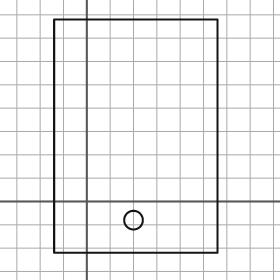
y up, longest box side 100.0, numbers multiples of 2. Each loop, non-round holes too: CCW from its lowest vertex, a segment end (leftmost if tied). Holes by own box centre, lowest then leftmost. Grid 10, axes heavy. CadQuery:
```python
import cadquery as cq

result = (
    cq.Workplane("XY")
    .moveTo(-14.0, -22.0)
    .lineTo(56.0, -22.0)
    .lineTo(56.0, 78.0)
    .lineTo(-14.0, 78.0)
    .close()
    .moveTo(20.0, -8.0)
    .circle(4.0)
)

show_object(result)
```